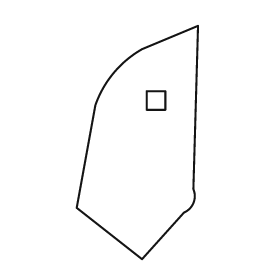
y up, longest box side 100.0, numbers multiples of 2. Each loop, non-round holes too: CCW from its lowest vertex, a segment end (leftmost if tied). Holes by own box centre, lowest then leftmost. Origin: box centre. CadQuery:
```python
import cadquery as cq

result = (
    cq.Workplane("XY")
    .moveTo(2.0, -50.0)
    .lineTo(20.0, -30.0)
    .threePointArc((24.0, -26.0), (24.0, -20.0))
    .lineTo(26.0, 50.0)
    .lineTo(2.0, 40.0)
    .threePointArc((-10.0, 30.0), (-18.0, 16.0))
    .lineTo(-26.0, -28.0)
    .close()
    .moveTo(4.0, 14.0)
    .lineTo(12.0, 14.0)
    .lineTo(12.0, 22.0)
    .lineTo(4.0, 22.0)
    .close()
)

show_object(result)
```